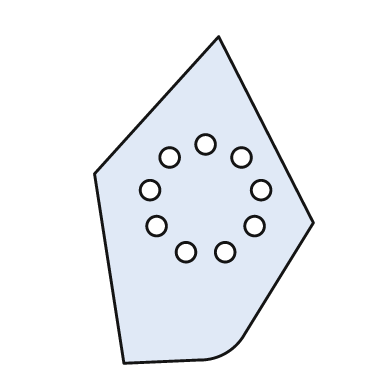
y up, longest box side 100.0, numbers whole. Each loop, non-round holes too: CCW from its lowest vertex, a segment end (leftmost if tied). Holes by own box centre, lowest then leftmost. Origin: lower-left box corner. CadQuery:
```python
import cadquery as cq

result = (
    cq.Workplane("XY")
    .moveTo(9.0, 0.0)
    .lineTo(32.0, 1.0)
    .threePointArc((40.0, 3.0), (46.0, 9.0))
    .lineTo(67.0, 43.0)
    .lineTo(38.0, 100.0)
    .lineTo(0.0, 58.0)
    .close()
    .moveTo(28.0, 34.0)
    .circle(3.0)
    .moveTo(40.0, 34.0)
    .circle(3.0)
    .moveTo(19.0, 42.0)
    .circle(3.0)
    .moveTo(49.0, 42.0)
    .circle(3.0)
    .moveTo(17.0, 53.0)
    .circle(3.0)
    .moveTo(51.0, 53.0)
    .circle(3.0)
    .moveTo(23.0, 63.0)
    .circle(3.0)
    .moveTo(45.0, 63.0)
    .circle(3.0)
    .moveTo(34.0, 67.0)
    .circle(3.0)
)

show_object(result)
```